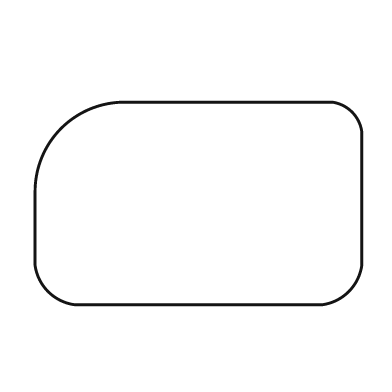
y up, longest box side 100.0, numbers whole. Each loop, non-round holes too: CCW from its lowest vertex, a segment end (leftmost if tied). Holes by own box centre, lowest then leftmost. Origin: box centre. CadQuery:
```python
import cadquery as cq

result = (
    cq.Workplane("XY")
    .moveTo(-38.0, -31.0)
    .lineTo(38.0, -31.0)
    .threePointArc((46.0, -27.0), (50.0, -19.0))
    .lineTo(50.0, 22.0)
    .threePointArc((47.0, 28.0), (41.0, 31.0))
    .lineTo(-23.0, 31.0)
    .threePointArc((-42.0, 23.0), (-50.0, 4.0))
    .lineTo(-50.0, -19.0)
    .threePointArc((-46.0, -27.0), (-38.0, -31.0))
    .close()
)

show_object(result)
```